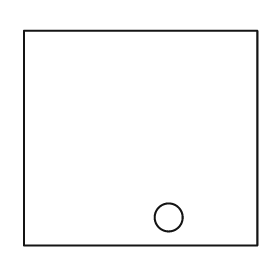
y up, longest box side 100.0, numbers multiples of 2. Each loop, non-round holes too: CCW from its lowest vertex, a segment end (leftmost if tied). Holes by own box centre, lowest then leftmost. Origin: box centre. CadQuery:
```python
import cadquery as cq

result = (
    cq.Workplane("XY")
    .moveTo(-50.0, -46.0)
    .lineTo(50.0, -46.0)
    .lineTo(50.0, 46.0)
    .lineTo(-50.0, 46.0)
    .close()
    .moveTo(12.0, -34.0)
    .circle(6.0)
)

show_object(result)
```